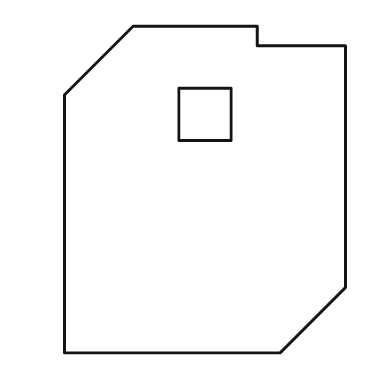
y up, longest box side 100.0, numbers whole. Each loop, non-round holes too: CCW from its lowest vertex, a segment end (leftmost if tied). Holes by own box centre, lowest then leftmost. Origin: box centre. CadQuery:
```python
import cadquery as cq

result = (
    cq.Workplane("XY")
    .moveTo(-43.0, -50.0)
    .lineTo(23.0, -50.0)
    .lineTo(43.0, -30.0)
    .lineTo(43.0, 44.0)
    .lineTo(16.0, 44.0)
    .lineTo(16.0, 50.0)
    .lineTo(-22.0, 50.0)
    .lineTo(-43.0, 29.0)
    .close()
    .moveTo(-8.0, 15.0)
    .lineTo(8.0, 15.0)
    .lineTo(8.0, 31.0)
    .lineTo(-8.0, 31.0)
    .close()
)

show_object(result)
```